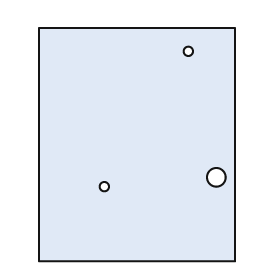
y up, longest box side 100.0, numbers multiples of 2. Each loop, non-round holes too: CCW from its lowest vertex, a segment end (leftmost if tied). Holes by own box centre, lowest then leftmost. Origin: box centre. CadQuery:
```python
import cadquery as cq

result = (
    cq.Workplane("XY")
    .moveTo(-42.0, -50.0)
    .lineTo(42.0, -50.0)
    .lineTo(42.0, 50.0)
    .lineTo(-42.0, 50.0)
    .close()
    .moveTo(-14.0, -18.0)
    .circle(2.0)
    .moveTo(34.0, -14.0)
    .circle(4.0)
    .moveTo(22.0, 40.0)
    .circle(2.0)
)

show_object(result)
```